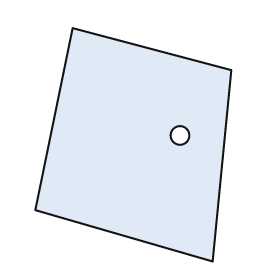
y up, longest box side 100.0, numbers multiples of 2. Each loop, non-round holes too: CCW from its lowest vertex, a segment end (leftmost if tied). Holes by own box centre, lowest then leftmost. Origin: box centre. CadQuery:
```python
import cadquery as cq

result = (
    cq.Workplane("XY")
    .moveTo(34.0, -50.0)
    .lineTo(42.0, 32.0)
    .lineTo(-26.0, 50.0)
    .lineTo(-42.0, -28.0)
    .close()
    .moveTo(20.0, 4.0)
    .circle(4.0)
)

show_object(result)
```